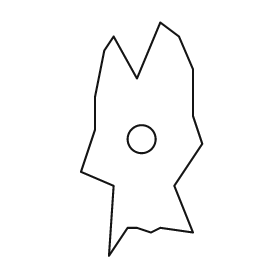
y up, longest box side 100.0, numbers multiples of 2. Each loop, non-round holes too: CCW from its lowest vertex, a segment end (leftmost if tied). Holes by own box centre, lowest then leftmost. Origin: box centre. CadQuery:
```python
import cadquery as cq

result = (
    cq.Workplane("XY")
    .moveTo(-14.0, -50.0)
    .lineTo(-6.0, -38.0)
    .lineTo(-2.0, -38.0)
    .lineTo(4.0, -40.0)
    .lineTo(8.0, -38.0)
    .lineTo(22.0, -40.0)
    .lineTo(14.0, -20.0)
    .lineTo(26.0, -2.0)
    .lineTo(22.0, 10.0)
    .lineTo(22.0, 30.0)
    .lineTo(16.0, 44.0)
    .lineTo(8.0, 50.0)
    .lineTo(-2.0, 26.0)
    .lineTo(-12.0, 44.0)
    .lineTo(-16.0, 38.0)
    .lineTo(-20.0, 18.0)
    .lineTo(-20.0, 4.0)
    .lineTo(-26.0, -14.0)
    .lineTo(-12.0, -20.0)
    .close()
    .moveTo(0.0, 0.0)
    .circle(6.0)
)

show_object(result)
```